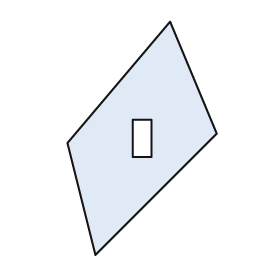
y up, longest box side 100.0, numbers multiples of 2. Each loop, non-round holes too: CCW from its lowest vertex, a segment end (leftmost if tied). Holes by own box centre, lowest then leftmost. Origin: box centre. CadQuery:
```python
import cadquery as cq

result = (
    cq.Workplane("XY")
    .moveTo(-20.0, -50.0)
    .lineTo(32.0, 2.0)
    .lineTo(12.0, 50.0)
    .lineTo(-32.0, -2.0)
    .close()
    .moveTo(-4.0, -8.0)
    .lineTo(4.0, -8.0)
    .lineTo(4.0, 8.0)
    .lineTo(-4.0, 8.0)
    .close()
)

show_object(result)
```